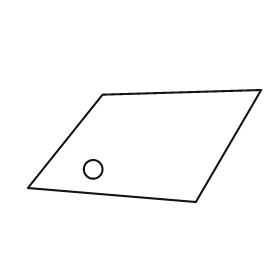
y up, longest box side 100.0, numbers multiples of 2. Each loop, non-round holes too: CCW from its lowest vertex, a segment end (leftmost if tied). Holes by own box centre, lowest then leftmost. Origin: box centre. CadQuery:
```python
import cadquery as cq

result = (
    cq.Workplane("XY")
    .moveTo(22.0, -24.0)
    .lineTo(50.0, 24.0)
    .lineTo(-18.0, 22.0)
    .lineTo(-50.0, -18.0)
    .close()
    .moveTo(-22.0, -10.0)
    .circle(4.0)
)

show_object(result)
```